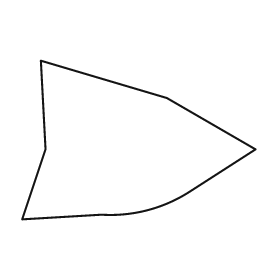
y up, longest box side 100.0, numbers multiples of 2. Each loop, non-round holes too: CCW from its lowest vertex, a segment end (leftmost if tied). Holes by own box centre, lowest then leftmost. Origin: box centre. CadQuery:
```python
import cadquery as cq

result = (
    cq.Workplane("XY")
    .moveTo(-50.0, -34.0)
    .lineTo(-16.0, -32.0)
    .threePointArc((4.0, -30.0), (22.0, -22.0))
    .lineTo(50.0, -4.0)
    .lineTo(12.0, 18.0)
    .lineTo(-42.0, 34.0)
    .lineTo(-40.0, -4.0)
    .close()
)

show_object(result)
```